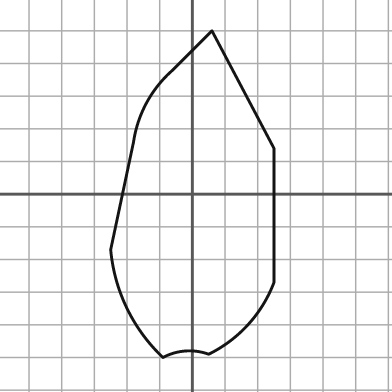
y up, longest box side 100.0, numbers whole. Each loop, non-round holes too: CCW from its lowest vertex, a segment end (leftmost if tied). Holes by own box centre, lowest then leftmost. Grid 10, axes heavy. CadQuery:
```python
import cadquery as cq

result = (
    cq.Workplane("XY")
    .moveTo(-9.0, -50.0)
    .threePointArc((-2.0, -48.0), (5.0, -49.0))
    .threePointArc((17.0, -40.0), (25.0, -27.0))
    .lineTo(25.0, 14.0)
    .lineTo(6.0, 50.0)
    .lineTo(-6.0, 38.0)
    .threePointArc((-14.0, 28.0), (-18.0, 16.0))
    .lineTo(-25.0, -17.0)
    .threePointArc((-20.0, -35.0), (-9.0, -50.0))
    .close()
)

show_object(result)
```